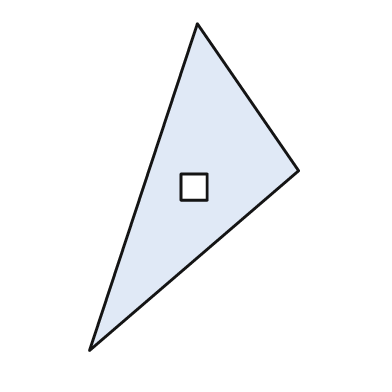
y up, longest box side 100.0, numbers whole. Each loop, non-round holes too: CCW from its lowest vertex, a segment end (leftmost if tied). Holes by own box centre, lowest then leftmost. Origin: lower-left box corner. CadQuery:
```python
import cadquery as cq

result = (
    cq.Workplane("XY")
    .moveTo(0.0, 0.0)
    .lineTo(64.0, 55.0)
    .lineTo(33.0, 100.0)
    .close()
    .moveTo(28.0, 46.0)
    .lineTo(36.0, 46.0)
    .lineTo(36.0, 54.0)
    .lineTo(28.0, 54.0)
    .close()
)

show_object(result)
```